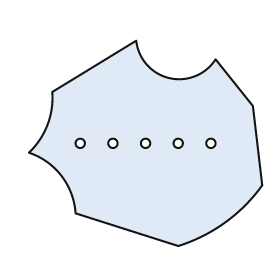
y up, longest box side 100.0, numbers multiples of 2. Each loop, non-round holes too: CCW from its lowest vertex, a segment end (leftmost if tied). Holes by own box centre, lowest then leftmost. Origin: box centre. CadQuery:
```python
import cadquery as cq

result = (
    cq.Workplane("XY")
    .moveTo(14.0, -44.0)
    .threePointArc((34.0, -34.0), (50.0, -18.0))
    .lineTo(46.0, 16.0)
    .lineTo(30.0, 36.0)
    .threePointArc((10.0, 28.0), (-4.0, 44.0))
    .lineTo(-40.0, 22.0)
    .threePointArc((-42.0, 8.0), (-50.0, -4.0))
    .threePointArc((-36.0, -14.0), (-30.0, -30.0))
    .close()
    .moveTo(-28.0, 0.0)
    .circle(2.0)
    .moveTo(-14.0, 0.0)
    .circle(2.0)
    .moveTo(0.0, 0.0)
    .circle(2.0)
    .moveTo(14.0, 0.0)
    .circle(2.0)
    .moveTo(28.0, 0.0)
    .circle(2.0)
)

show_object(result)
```